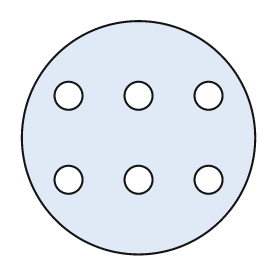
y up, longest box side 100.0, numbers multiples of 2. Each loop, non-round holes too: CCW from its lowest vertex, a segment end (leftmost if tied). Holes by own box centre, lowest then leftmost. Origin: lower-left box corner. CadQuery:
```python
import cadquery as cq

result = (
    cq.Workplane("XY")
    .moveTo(50.0, 50.0)
    .circle(50.0)
    .moveTo(20.0, 32.0)
    .circle(6.0)
    .moveTo(50.0, 32.0)
    .circle(6.0)
    .moveTo(80.0, 32.0)
    .circle(6.0)
    .moveTo(20.0, 68.0)
    .circle(6.0)
    .moveTo(50.0, 68.0)
    .circle(6.0)
    .moveTo(80.0, 68.0)
    .circle(6.0)
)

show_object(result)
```